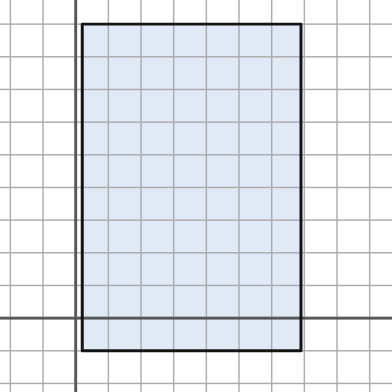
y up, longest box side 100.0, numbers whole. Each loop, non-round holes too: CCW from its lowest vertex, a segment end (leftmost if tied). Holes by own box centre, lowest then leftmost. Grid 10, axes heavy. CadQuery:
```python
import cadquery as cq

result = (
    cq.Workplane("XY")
    .moveTo(2.0, -10.0)
    .lineTo(69.0, -10.0)
    .lineTo(69.0, 90.0)
    .lineTo(2.0, 90.0)
    .close()
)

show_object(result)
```